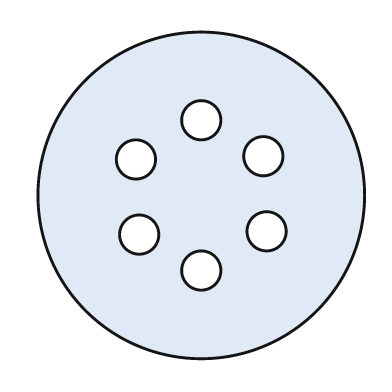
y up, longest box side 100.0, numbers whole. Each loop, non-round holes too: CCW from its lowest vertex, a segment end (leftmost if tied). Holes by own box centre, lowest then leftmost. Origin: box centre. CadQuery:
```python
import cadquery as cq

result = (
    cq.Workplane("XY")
    .moveTo(0.0, 0.0)
    .circle(50.0)
    .moveTo(0.0, -23.0)
    .circle(6.0)
    .moveTo(-19.0, -12.0)
    .circle(6.0)
    .moveTo(20.0, -11.0)
    .circle(6.0)
    .moveTo(-20.0, 11.0)
    .circle(6.0)
    .moveTo(19.0, 12.0)
    .circle(6.0)
    .moveTo(0.0, 23.0)
    .circle(6.0)
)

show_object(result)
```